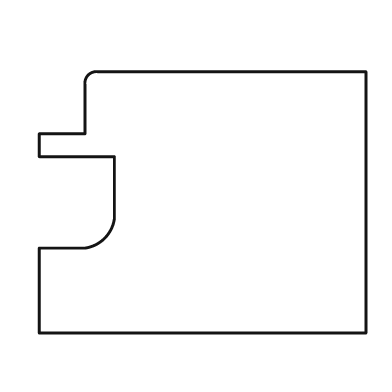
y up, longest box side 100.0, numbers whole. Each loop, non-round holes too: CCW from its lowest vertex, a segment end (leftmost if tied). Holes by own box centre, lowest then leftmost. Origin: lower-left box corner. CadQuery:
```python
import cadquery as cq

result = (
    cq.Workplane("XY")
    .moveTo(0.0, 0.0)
    .lineTo(100.0, 0.0)
    .lineTo(100.0, 80.0)
    .lineTo(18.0, 80.0)
    .threePointArc((15.0, 79.0), (14.0, 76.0))
    .lineTo(14.0, 61.0)
    .lineTo(0.0, 61.0)
    .lineTo(0.0, 54.0)
    .lineTo(23.0, 54.0)
    .lineTo(23.0, 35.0)
    .threePointArc((20.0, 29.0), (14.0, 26.0))
    .lineTo(0.0, 26.0)
    .close()
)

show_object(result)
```